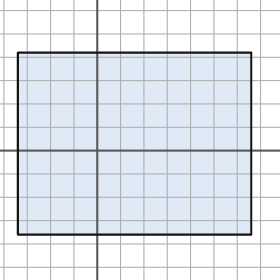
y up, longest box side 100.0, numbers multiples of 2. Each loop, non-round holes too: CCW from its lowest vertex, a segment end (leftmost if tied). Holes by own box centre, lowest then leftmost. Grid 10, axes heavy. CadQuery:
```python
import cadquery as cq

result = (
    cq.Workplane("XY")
    .moveTo(-34.0, -36.0)
    .lineTo(66.0, -36.0)
    .lineTo(66.0, 42.0)
    .lineTo(-34.0, 42.0)
    .close()
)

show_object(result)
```